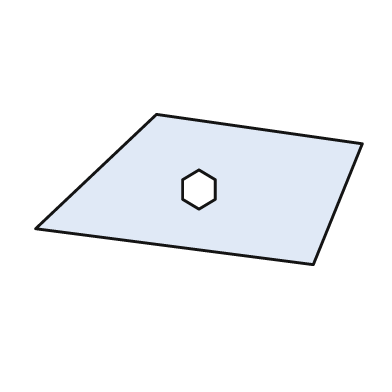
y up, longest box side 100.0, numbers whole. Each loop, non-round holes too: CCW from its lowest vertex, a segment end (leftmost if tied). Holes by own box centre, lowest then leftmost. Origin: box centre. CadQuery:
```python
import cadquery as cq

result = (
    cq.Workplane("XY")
    .moveTo(35.0, -23.0)
    .lineTo(50.0, 14.0)
    .lineTo(-13.0, 23.0)
    .lineTo(-50.0, -12.0)
    .close()
    .moveTo(0.0, -6.0)
    .lineTo(5.0, -3.0)
    .lineTo(5.0, 3.0)
    .lineTo(0.0, 6.0)
    .lineTo(-5.0, 3.0)
    .lineTo(-5.0, -3.0)
    .close()
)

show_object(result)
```